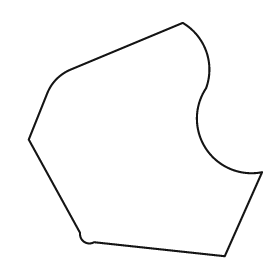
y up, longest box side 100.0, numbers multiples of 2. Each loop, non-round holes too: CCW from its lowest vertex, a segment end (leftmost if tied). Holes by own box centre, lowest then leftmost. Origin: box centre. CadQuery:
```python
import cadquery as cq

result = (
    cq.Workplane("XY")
    .moveTo(34.0, -50.0)
    .lineTo(50.0, -14.0)
    .threePointArc((26.0, -4.0), (26.0, 22.0))
    .threePointArc((26.0, 38.0), (16.0, 50.0))
    .lineTo(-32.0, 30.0)
    .threePointArc((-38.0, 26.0), (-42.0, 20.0))
    .lineTo(-50.0, 0.0)
    .lineTo(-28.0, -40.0)
    .threePointArc((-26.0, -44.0), (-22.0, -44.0))
    .close()
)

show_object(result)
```